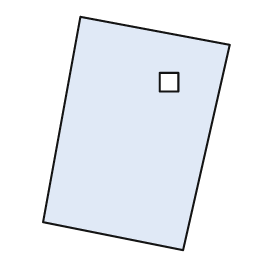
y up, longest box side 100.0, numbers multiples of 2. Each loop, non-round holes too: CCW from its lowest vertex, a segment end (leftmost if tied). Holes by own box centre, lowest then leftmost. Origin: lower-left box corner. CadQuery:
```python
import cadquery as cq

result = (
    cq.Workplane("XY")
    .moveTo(60.0, 0.0)
    .lineTo(80.0, 88.0)
    .lineTo(16.0, 100.0)
    .lineTo(0.0, 12.0)
    .close()
    .moveTo(50.0, 68.0)
    .lineTo(58.0, 68.0)
    .lineTo(58.0, 76.0)
    .lineTo(50.0, 76.0)
    .close()
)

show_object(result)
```